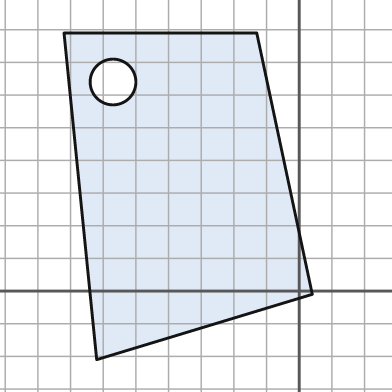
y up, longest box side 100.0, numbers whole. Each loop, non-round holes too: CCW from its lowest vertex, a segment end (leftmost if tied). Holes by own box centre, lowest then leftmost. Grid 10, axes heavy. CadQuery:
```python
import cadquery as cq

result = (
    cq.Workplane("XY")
    .moveTo(-62.0, -21.0)
    .lineTo(4.0, -1.0)
    .lineTo(-13.0, 79.0)
    .lineTo(-72.0, 79.0)
    .close()
    .moveTo(-57.0, 64.0)
    .circle(7.0)
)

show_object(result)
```